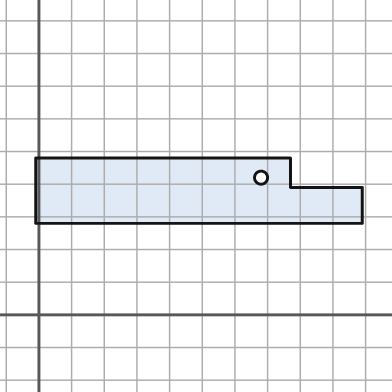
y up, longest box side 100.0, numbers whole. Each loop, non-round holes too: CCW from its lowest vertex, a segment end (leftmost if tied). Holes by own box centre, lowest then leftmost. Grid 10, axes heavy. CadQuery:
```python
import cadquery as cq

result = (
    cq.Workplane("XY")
    .moveTo(-1.0, 28.0)
    .lineTo(99.0, 28.0)
    .lineTo(99.0, 39.0)
    .lineTo(77.0, 39.0)
    .lineTo(77.0, 48.0)
    .lineTo(-1.0, 48.0)
    .close()
    .moveTo(68.0, 42.0)
    .circle(2.0)
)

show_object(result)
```